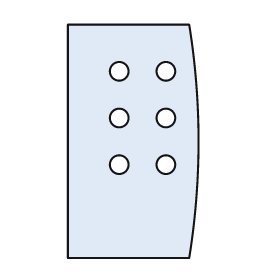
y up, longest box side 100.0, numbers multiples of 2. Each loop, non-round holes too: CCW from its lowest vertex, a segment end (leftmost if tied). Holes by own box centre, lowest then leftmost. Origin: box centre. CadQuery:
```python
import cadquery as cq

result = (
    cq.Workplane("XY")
    .moveTo(-28.0, -50.0)
    .lineTo(24.0, -50.0)
    .threePointArc((28.0, 0.0), (24.0, 50.0))
    .lineTo(-28.0, 50.0)
    .close()
    .moveTo(-6.0, -10.0)
    .circle(4.0)
    .moveTo(14.0, -10.0)
    .circle(4.0)
    .moveTo(-6.0, 10.0)
    .circle(4.0)
    .moveTo(14.0, 10.0)
    .circle(4.0)
    .moveTo(-6.0, 30.0)
    .circle(4.0)
    .moveTo(14.0, 30.0)
    .circle(4.0)
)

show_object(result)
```